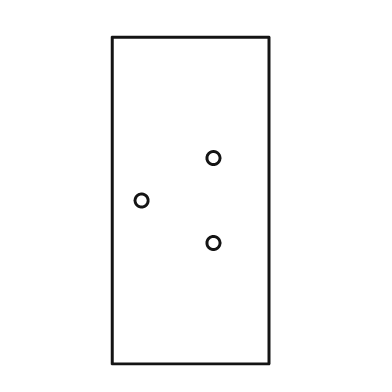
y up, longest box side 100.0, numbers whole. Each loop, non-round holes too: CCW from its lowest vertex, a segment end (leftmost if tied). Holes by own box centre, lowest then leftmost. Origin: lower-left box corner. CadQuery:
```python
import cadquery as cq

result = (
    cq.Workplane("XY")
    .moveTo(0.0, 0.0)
    .lineTo(48.0, 0.0)
    .lineTo(48.0, 100.0)
    .lineTo(0.0, 100.0)
    .close()
    .moveTo(31.0, 37.0)
    .circle(2.0)
    .moveTo(9.0, 50.0)
    .circle(2.0)
    .moveTo(31.0, 63.0)
    .circle(2.0)
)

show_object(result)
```